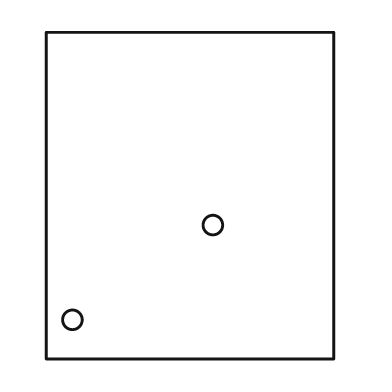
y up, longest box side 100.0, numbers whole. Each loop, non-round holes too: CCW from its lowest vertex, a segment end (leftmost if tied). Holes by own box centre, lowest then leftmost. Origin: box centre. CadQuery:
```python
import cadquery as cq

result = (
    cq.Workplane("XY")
    .moveTo(-44.0, -50.0)
    .lineTo(44.0, -50.0)
    .lineTo(44.0, 50.0)
    .lineTo(-44.0, 50.0)
    .close()
    .moveTo(-36.0, -38.0)
    .circle(3.0)
    .moveTo(7.0, -9.0)
    .circle(3.0)
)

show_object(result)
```